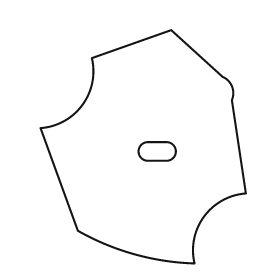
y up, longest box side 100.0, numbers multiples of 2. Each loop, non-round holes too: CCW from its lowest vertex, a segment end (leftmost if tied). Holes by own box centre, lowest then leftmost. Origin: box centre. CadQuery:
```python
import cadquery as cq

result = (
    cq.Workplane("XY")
    .moveTo(22.0, -50.0)
    .threePointArc((26.0, -30.0), (44.0, -20.0))
    .lineTo(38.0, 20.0)
    .threePointArc((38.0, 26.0), (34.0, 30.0))
    .lineTo(12.0, 50.0)
    .lineTo(-22.0, 38.0)
    .threePointArc((-26.0, 18.0), (-44.0, 8.0))
    .lineTo(-28.0, -36.0)
    .threePointArc((-4.0, -46.0), (22.0, -50.0))
    .close()
    .moveTo(2.0, -6.0)
    .lineTo(10.0, -6.0)
    .threePointArc((14.0, -2.0), (10.0, 2.0))
    .lineTo(2.0, 2.0)
    .threePointArc((-2.0, -2.0), (2.0, -6.0))
    .close()
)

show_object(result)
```